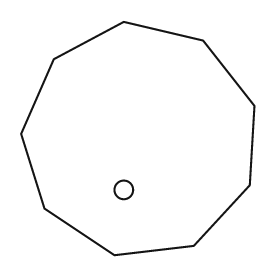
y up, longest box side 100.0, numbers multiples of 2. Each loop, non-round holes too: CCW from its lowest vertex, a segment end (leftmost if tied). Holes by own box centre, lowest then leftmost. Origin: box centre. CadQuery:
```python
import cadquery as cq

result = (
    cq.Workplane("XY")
    .moveTo(-10.0, -50.0)
    .lineTo(24.0, -46.0)
    .lineTo(48.0, -20.0)
    .lineTo(50.0, 14.0)
    .lineTo(28.0, 42.0)
    .lineTo(-6.0, 50.0)
    .lineTo(-36.0, 34.0)
    .lineTo(-50.0, 2.0)
    .lineTo(-40.0, -30.0)
    .close()
    .moveTo(-6.0, -22.0)
    .circle(4.0)
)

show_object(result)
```